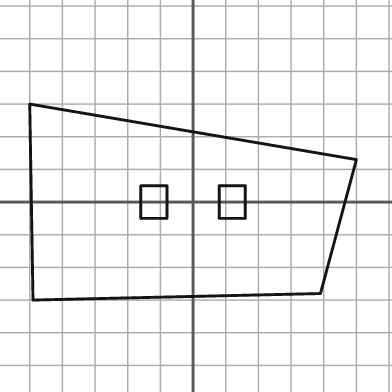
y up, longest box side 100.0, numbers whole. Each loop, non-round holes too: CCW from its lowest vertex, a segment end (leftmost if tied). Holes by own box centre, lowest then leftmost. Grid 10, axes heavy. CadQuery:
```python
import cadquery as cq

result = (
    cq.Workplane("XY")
    .moveTo(-49.0, -30.0)
    .lineTo(39.0, -28.0)
    .lineTo(50.0, 13.0)
    .lineTo(-50.0, 30.0)
    .close()
    .moveTo(-16.0, -5.0)
    .lineTo(-8.0, -5.0)
    .lineTo(-8.0, 5.0)
    .lineTo(-16.0, 5.0)
    .close()
    .moveTo(8.0, -5.0)
    .lineTo(16.0, -5.0)
    .lineTo(16.0, 5.0)
    .lineTo(8.0, 5.0)
    .close()
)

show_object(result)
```